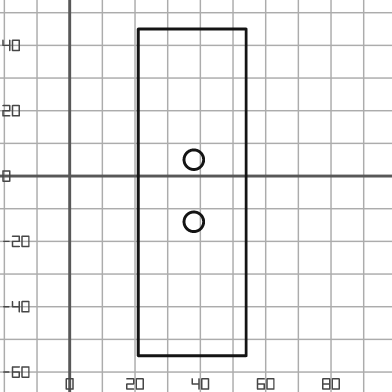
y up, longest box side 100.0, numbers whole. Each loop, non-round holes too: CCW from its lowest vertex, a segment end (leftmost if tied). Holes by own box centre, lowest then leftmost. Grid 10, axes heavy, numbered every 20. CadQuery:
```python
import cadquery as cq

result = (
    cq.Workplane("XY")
    .moveTo(21.0, -55.0)
    .lineTo(54.0, -55.0)
    .lineTo(54.0, 45.0)
    .lineTo(21.0, 45.0)
    .close()
    .moveTo(38.0, -14.0)
    .circle(3.0)
    .moveTo(38.0, 5.0)
    .circle(3.0)
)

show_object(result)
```